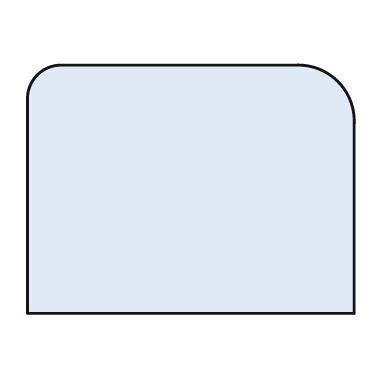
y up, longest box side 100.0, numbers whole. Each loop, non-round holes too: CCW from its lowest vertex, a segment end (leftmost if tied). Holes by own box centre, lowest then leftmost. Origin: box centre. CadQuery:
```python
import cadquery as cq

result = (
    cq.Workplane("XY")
    .moveTo(-50.0, -38.0)
    .lineTo(50.0, -38.0)
    .lineTo(50.0, 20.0)
    .threePointArc((45.0, 33.0), (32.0, 38.0))
    .lineTo(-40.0, 38.0)
    .threePointArc((-47.0, 35.0), (-50.0, 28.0))
    .close()
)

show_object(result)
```